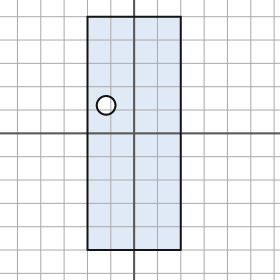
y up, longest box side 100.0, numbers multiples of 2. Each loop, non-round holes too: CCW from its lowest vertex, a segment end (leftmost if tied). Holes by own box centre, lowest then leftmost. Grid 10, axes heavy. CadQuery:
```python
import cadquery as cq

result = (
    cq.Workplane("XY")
    .moveTo(-20.0, -50.0)
    .lineTo(20.0, -50.0)
    .lineTo(20.0, 50.0)
    .lineTo(-20.0, 50.0)
    .close()
    .moveTo(-12.0, 12.0)
    .circle(4.0)
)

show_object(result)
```